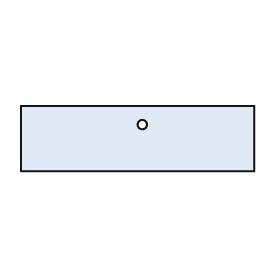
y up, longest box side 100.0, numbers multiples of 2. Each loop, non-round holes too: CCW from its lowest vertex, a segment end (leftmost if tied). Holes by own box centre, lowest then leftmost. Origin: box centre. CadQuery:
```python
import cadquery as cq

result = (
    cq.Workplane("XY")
    .moveTo(-50.0, -14.0)
    .lineTo(50.0, -14.0)
    .lineTo(50.0, 14.0)
    .lineTo(-50.0, 14.0)
    .close()
    .moveTo(2.0, 6.0)
    .circle(2.0)
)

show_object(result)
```